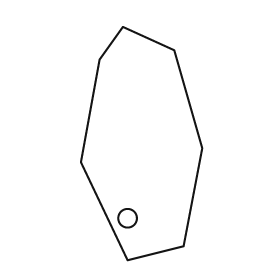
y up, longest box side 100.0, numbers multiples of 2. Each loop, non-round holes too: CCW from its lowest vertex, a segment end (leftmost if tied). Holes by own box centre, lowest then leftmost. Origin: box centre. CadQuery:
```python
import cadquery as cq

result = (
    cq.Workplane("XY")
    .moveTo(-6.0, -50.0)
    .lineTo(18.0, -44.0)
    .lineTo(26.0, -2.0)
    .lineTo(14.0, 40.0)
    .lineTo(-8.0, 50.0)
    .lineTo(-18.0, 36.0)
    .lineTo(-26.0, -8.0)
    .close()
    .moveTo(-6.0, -32.0)
    .circle(4.0)
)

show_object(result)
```